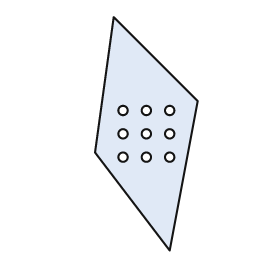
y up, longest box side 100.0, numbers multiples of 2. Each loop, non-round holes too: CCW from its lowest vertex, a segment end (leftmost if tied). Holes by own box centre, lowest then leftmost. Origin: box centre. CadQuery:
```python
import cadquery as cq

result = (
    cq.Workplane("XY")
    .moveTo(10.0, -50.0)
    .lineTo(22.0, 14.0)
    .lineTo(-14.0, 50.0)
    .lineTo(-22.0, -8.0)
    .close()
    .moveTo(-10.0, -10.0)
    .circle(2.0)
    .moveTo(0.0, -10.0)
    .circle(2.0)
    .moveTo(10.0, -10.0)
    .circle(2.0)
    .moveTo(-10.0, 0.0)
    .circle(2.0)
    .moveTo(0.0, 0.0)
    .circle(2.0)
    .moveTo(10.0, 0.0)
    .circle(2.0)
    .moveTo(-10.0, 10.0)
    .circle(2.0)
    .moveTo(0.0, 10.0)
    .circle(2.0)
    .moveTo(10.0, 10.0)
    .circle(2.0)
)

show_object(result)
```